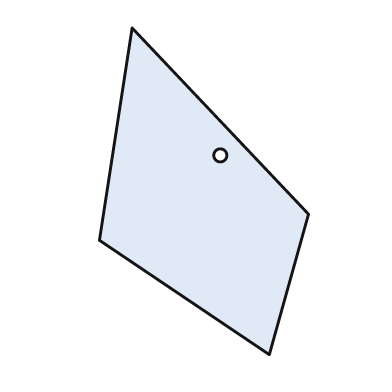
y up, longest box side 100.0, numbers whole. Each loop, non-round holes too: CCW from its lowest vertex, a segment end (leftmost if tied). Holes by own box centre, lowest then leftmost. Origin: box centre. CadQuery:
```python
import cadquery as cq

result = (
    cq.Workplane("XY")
    .moveTo(20.0, -50.0)
    .lineTo(32.0, -7.0)
    .lineTo(-22.0, 50.0)
    .lineTo(-32.0, -15.0)
    .close()
    .moveTo(5.0, 11.0)
    .circle(2.0)
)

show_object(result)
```